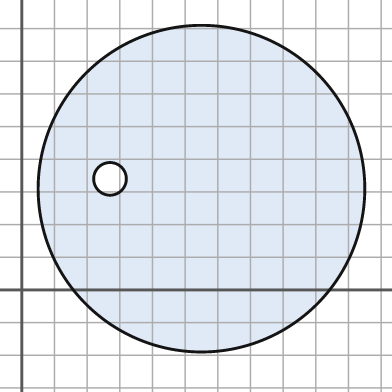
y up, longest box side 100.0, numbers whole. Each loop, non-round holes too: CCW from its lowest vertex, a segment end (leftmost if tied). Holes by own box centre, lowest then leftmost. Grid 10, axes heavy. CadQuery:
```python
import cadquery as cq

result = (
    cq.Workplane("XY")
    .moveTo(55.0, 31.0)
    .circle(50.0)
    .moveTo(27.0, 34.0)
    .circle(5.0)
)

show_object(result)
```